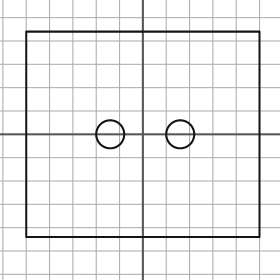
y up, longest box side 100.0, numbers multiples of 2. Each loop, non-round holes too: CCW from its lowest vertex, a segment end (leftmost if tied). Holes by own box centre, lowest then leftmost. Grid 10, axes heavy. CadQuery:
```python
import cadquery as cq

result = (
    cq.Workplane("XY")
    .moveTo(-50.0, -44.0)
    .lineTo(50.0, -44.0)
    .lineTo(50.0, 44.0)
    .lineTo(-50.0, 44.0)
    .close()
    .moveTo(-14.0, 0.0)
    .circle(6.0)
    .moveTo(16.0, 0.0)
    .circle(6.0)
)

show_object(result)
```